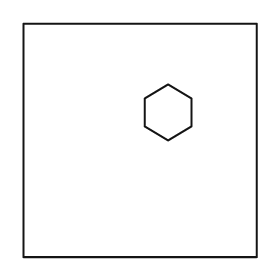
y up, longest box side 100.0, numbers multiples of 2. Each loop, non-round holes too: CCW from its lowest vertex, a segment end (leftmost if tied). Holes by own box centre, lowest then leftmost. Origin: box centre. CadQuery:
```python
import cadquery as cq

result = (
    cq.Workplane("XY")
    .moveTo(-50.0, -50.0)
    .lineTo(50.0, -50.0)
    .lineTo(50.0, 50.0)
    .lineTo(-50.0, 50.0)
    .close()
    .moveTo(12.0, 0.0)
    .lineTo(22.0, 6.0)
    .lineTo(22.0, 18.0)
    .lineTo(12.0, 24.0)
    .lineTo(2.0, 18.0)
    .lineTo(2.0, 6.0)
    .close()
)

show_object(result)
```